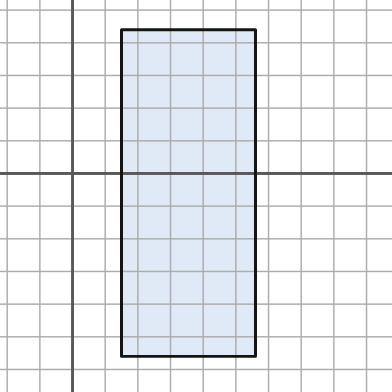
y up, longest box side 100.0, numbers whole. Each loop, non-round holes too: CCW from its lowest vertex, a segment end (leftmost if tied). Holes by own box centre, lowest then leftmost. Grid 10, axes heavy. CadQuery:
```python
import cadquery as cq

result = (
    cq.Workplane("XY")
    .moveTo(15.0, -56.0)
    .lineTo(56.0, -56.0)
    .lineTo(56.0, 44.0)
    .lineTo(15.0, 44.0)
    .close()
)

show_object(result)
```